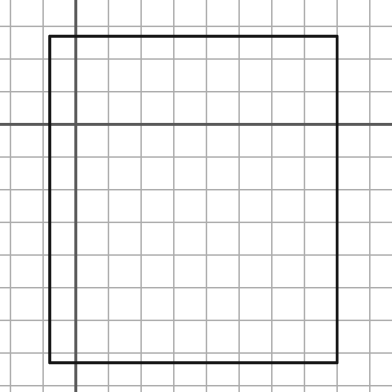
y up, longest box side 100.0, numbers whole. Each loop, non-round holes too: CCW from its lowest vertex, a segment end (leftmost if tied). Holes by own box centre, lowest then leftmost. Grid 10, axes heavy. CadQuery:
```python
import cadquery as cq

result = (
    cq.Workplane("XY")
    .moveTo(-8.0, -73.0)
    .lineTo(80.0, -73.0)
    .lineTo(80.0, 27.0)
    .lineTo(-8.0, 27.0)
    .close()
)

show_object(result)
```